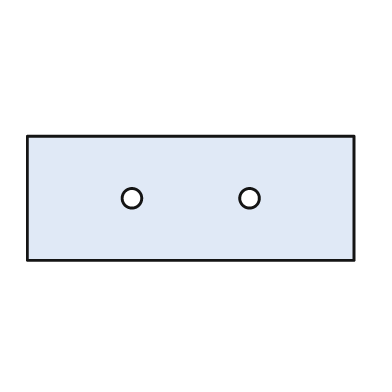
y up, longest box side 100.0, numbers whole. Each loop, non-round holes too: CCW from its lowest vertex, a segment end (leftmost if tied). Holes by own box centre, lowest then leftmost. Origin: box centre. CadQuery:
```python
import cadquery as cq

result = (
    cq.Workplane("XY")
    .moveTo(-50.0, -19.0)
    .lineTo(50.0, -19.0)
    .lineTo(50.0, 19.0)
    .lineTo(-50.0, 19.0)
    .close()
    .moveTo(-18.0, 0.0)
    .circle(3.0)
    .moveTo(18.0, 0.0)
    .circle(3.0)
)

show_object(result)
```